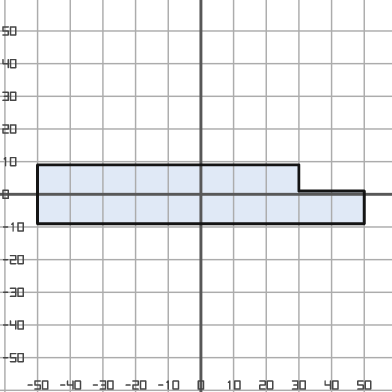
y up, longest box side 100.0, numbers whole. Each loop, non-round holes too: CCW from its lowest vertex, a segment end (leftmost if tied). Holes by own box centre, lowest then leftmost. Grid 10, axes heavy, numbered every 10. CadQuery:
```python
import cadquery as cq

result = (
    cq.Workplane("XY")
    .moveTo(-50.0, -9.0)
    .lineTo(50.0, -9.0)
    .lineTo(50.0, 1.0)
    .lineTo(30.0, 1.0)
    .lineTo(30.0, 9.0)
    .lineTo(-50.0, 9.0)
    .close()
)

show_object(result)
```